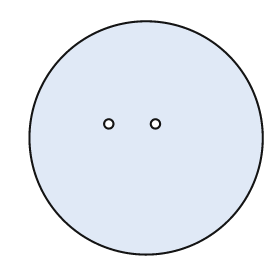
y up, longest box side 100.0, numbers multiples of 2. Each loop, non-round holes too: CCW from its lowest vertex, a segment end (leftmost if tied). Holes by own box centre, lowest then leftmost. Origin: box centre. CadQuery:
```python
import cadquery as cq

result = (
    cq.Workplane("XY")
    .moveTo(0.0, 0.0)
    .circle(50.0)
    .moveTo(-16.0, 6.0)
    .circle(2.0)
    .moveTo(4.0, 6.0)
    .circle(2.0)
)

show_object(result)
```